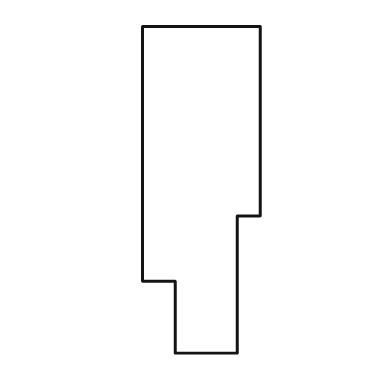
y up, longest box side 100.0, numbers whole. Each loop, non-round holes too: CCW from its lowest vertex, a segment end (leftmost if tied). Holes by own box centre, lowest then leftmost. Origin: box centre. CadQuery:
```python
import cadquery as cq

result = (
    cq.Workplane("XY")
    .moveTo(-8.0, -50.0)
    .lineTo(11.0, -50.0)
    .lineTo(11.0, -8.0)
    .lineTo(18.0, -8.0)
    .lineTo(18.0, 50.0)
    .lineTo(-18.0, 50.0)
    .lineTo(-18.0, -28.0)
    .lineTo(-8.0, -28.0)
    .close()
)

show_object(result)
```